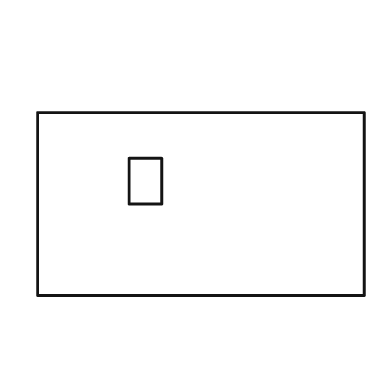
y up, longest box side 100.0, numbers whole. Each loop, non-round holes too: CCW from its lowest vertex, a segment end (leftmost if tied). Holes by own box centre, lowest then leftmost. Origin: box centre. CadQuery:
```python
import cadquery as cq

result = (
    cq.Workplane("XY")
    .moveTo(-50.0, -28.0)
    .lineTo(50.0, -28.0)
    .lineTo(50.0, 28.0)
    .lineTo(-50.0, 28.0)
    .close()
    .moveTo(-22.0, 0.0)
    .lineTo(-12.0, 0.0)
    .lineTo(-12.0, 14.0)
    .lineTo(-22.0, 14.0)
    .close()
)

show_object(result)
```